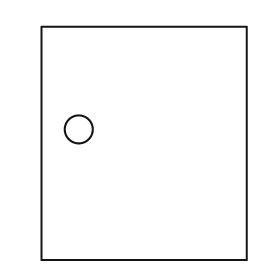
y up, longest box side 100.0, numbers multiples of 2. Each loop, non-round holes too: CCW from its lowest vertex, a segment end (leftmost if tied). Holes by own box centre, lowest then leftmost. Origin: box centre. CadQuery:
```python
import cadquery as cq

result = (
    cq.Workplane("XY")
    .moveTo(-44.0, -50.0)
    .lineTo(44.0, -50.0)
    .lineTo(44.0, 50.0)
    .lineTo(-44.0, 50.0)
    .close()
    .moveTo(-28.0, 6.0)
    .circle(6.0)
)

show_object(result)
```